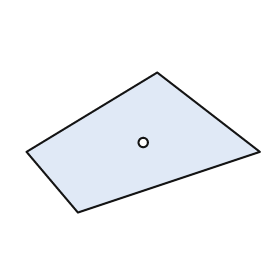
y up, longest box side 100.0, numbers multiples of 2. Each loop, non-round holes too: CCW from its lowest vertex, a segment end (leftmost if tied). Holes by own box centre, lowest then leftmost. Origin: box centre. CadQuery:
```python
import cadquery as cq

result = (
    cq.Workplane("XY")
    .moveTo(-28.0, -30.0)
    .lineTo(50.0, -4.0)
    .lineTo(6.0, 30.0)
    .lineTo(-50.0, -4.0)
    .close()
    .moveTo(0.0, 0.0)
    .circle(2.0)
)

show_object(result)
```